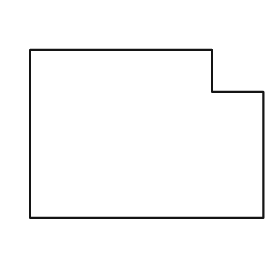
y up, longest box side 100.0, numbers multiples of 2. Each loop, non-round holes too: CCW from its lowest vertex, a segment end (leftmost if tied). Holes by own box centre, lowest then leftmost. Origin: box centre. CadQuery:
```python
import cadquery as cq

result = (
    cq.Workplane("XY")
    .moveTo(-50.0, -36.0)
    .lineTo(50.0, -36.0)
    .lineTo(50.0, 18.0)
    .lineTo(28.0, 18.0)
    .lineTo(28.0, 36.0)
    .lineTo(-50.0, 36.0)
    .close()
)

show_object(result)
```